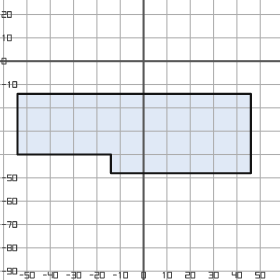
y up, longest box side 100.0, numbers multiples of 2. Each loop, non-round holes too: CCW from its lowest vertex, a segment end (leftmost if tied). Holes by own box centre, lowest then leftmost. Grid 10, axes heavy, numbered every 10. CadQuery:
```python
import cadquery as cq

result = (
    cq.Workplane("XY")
    .moveTo(-14.0, -48.0)
    .lineTo(46.0, -48.0)
    .lineTo(46.0, -14.0)
    .lineTo(-54.0, -14.0)
    .lineTo(-54.0, -40.0)
    .lineTo(-14.0, -40.0)
    .close()
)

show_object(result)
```